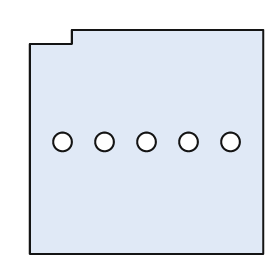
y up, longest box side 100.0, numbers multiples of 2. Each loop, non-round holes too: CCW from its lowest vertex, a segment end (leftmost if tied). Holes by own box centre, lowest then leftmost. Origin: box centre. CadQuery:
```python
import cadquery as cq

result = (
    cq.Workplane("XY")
    .moveTo(-50.0, -48.0)
    .lineTo(50.0, -48.0)
    .lineTo(50.0, 48.0)
    .lineTo(-32.0, 48.0)
    .lineTo(-32.0, 42.0)
    .lineTo(-50.0, 42.0)
    .close()
    .moveTo(-36.0, 0.0)
    .circle(4.0)
    .moveTo(-18.0, 0.0)
    .circle(4.0)
    .moveTo(0.0, 0.0)
    .circle(4.0)
    .moveTo(18.0, 0.0)
    .circle(4.0)
    .moveTo(36.0, 0.0)
    .circle(4.0)
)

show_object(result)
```